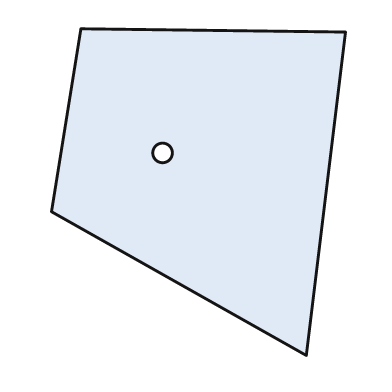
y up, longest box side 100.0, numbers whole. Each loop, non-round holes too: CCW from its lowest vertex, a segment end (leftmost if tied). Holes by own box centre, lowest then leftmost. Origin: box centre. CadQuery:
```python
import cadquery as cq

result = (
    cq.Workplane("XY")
    .moveTo(33.0, -50.0)
    .lineTo(45.0, 49.0)
    .lineTo(-36.0, 50.0)
    .lineTo(-45.0, -6.0)
    .close()
    .moveTo(-11.0, 12.0)
    .circle(3.0)
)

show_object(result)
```